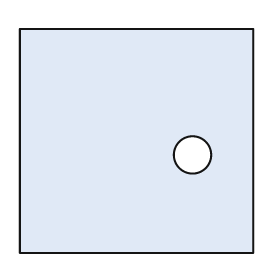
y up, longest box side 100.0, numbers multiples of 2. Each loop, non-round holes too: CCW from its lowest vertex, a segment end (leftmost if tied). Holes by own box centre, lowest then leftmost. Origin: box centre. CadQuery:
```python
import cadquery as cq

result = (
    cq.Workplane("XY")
    .moveTo(-50.0, -48.0)
    .lineTo(50.0, -48.0)
    .lineTo(50.0, 48.0)
    .lineTo(-50.0, 48.0)
    .close()
    .moveTo(24.0, -6.0)
    .circle(8.0)
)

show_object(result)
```